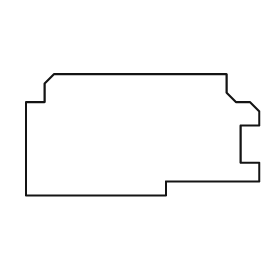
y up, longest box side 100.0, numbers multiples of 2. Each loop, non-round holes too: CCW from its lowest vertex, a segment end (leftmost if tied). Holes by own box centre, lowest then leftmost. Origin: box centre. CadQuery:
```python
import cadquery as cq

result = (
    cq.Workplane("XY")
    .moveTo(-50.0, -26.0)
    .lineTo(10.0, -26.0)
    .lineTo(10.0, -20.0)
    .lineTo(50.0, -20.0)
    .lineTo(50.0, -12.0)
    .lineTo(42.0, -12.0)
    .lineTo(42.0, 4.0)
    .lineTo(50.0, 4.0)
    .lineTo(50.0, 10.0)
    .lineTo(46.0, 14.0)
    .lineTo(40.0, 14.0)
    .lineTo(36.0, 18.0)
    .lineTo(36.0, 26.0)
    .lineTo(-38.0, 26.0)
    .lineTo(-42.0, 22.0)
    .lineTo(-42.0, 14.0)
    .lineTo(-50.0, 14.0)
    .close()
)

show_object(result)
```